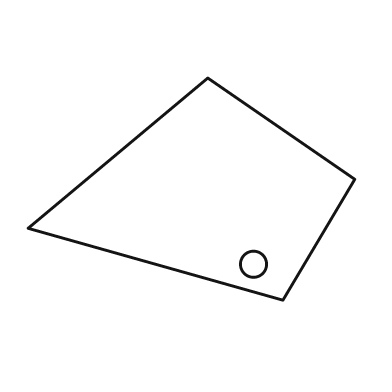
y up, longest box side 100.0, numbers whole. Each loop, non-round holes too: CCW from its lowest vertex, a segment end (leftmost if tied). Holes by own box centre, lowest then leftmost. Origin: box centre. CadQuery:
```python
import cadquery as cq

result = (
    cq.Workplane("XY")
    .moveTo(28.0, -34.0)
    .lineTo(50.0, 3.0)
    .lineTo(5.0, 34.0)
    .lineTo(-50.0, -12.0)
    .close()
    .moveTo(19.0, -23.0)
    .circle(4.0)
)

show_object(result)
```